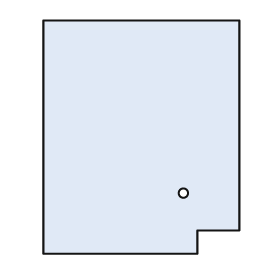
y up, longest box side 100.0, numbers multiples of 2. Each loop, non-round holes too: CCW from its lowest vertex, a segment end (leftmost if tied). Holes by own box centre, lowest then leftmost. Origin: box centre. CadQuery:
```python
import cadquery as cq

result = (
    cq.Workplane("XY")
    .moveTo(-42.0, -50.0)
    .lineTo(24.0, -50.0)
    .lineTo(24.0, -40.0)
    .lineTo(42.0, -40.0)
    .lineTo(42.0, 50.0)
    .lineTo(-42.0, 50.0)
    .close()
    .moveTo(18.0, -24.0)
    .circle(2.0)
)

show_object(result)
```